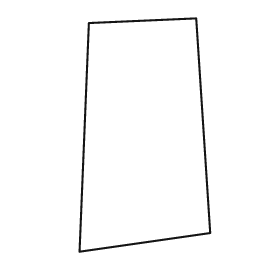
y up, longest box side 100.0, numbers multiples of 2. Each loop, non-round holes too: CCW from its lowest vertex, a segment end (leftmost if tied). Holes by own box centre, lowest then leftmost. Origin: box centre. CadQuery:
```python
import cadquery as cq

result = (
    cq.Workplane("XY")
    .moveTo(-28.0, -50.0)
    .lineTo(28.0, -42.0)
    .lineTo(22.0, 50.0)
    .lineTo(-24.0, 48.0)
    .close()
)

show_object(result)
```